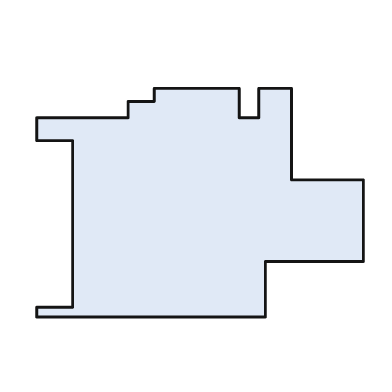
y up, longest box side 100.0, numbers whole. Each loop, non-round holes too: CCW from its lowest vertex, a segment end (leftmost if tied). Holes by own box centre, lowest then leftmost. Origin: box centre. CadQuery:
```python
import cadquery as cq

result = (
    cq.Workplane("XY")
    .moveTo(-50.0, -35.0)
    .lineTo(20.0, -35.0)
    .lineTo(20.0, -18.0)
    .lineTo(50.0, -18.0)
    .lineTo(50.0, 7.0)
    .lineTo(28.0, 7.0)
    .lineTo(28.0, 35.0)
    .lineTo(18.0, 35.0)
    .lineTo(18.0, 26.0)
    .lineTo(12.0, 26.0)
    .lineTo(12.0, 35.0)
    .lineTo(-14.0, 35.0)
    .lineTo(-14.0, 31.0)
    .lineTo(-22.0, 31.0)
    .lineTo(-22.0, 26.0)
    .lineTo(-50.0, 26.0)
    .lineTo(-50.0, 19.0)
    .lineTo(-39.0, 19.0)
    .lineTo(-39.0, -32.0)
    .lineTo(-50.0, -32.0)
    .close()
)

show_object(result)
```